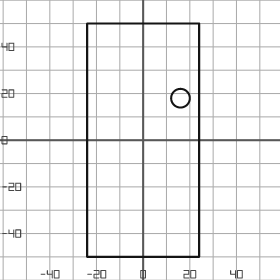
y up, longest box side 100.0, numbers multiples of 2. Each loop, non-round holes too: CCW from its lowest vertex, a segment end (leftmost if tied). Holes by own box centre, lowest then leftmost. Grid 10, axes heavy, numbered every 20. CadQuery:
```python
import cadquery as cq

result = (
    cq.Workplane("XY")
    .moveTo(-24.0, -50.0)
    .lineTo(24.0, -50.0)
    .lineTo(24.0, 50.0)
    .lineTo(-24.0, 50.0)
    .close()
    .moveTo(16.0, 18.0)
    .circle(4.0)
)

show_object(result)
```